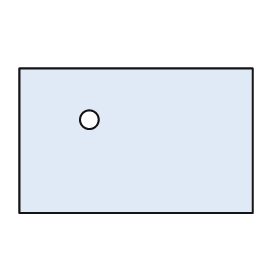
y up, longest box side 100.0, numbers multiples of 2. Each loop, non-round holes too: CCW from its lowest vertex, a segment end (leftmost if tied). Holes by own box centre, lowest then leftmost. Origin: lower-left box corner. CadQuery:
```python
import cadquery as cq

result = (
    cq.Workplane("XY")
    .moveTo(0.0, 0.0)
    .lineTo(100.0, 0.0)
    .lineTo(100.0, 62.0)
    .lineTo(0.0, 62.0)
    .close()
    .moveTo(30.0, 40.0)
    .circle(4.0)
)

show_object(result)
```